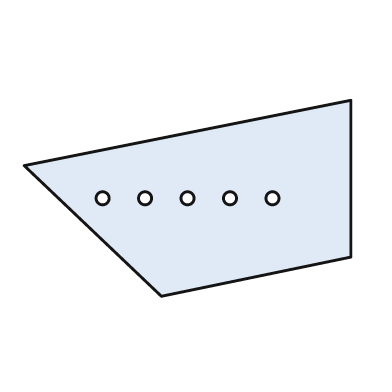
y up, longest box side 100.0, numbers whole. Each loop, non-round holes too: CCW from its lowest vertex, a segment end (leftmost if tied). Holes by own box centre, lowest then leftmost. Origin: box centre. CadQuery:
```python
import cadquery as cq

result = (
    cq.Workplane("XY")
    .moveTo(-8.0, -30.0)
    .lineTo(50.0, -18.0)
    .lineTo(50.0, 30.0)
    .lineTo(-50.0, 10.0)
    .close()
    .moveTo(-26.0, 0.0)
    .circle(2.0)
    .moveTo(-13.0, 0.0)
    .circle(2.0)
    .moveTo(0.0, 0.0)
    .circle(2.0)
    .moveTo(13.0, 0.0)
    .circle(2.0)
    .moveTo(26.0, 0.0)
    .circle(2.0)
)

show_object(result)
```